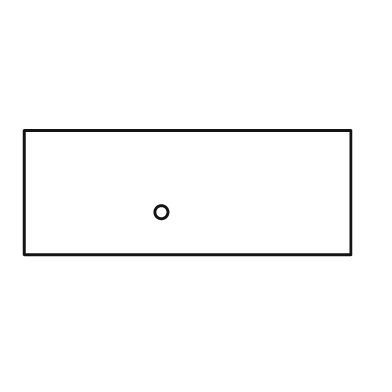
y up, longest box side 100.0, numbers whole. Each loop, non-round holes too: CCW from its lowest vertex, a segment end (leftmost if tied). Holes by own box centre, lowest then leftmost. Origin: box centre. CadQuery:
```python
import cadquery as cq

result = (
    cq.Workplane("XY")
    .moveTo(-50.0, -19.0)
    .lineTo(50.0, -19.0)
    .lineTo(50.0, 19.0)
    .lineTo(-50.0, 19.0)
    .close()
    .moveTo(-8.0, -6.0)
    .circle(2.0)
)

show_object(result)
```